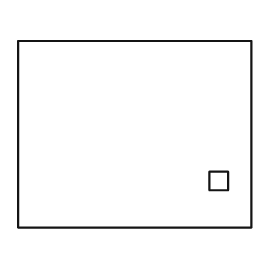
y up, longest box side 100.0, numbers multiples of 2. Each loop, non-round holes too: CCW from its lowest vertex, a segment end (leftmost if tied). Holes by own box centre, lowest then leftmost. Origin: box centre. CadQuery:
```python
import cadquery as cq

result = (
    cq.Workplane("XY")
    .moveTo(-50.0, -40.0)
    .lineTo(50.0, -40.0)
    .lineTo(50.0, 40.0)
    .lineTo(-50.0, 40.0)
    .close()
    .moveTo(32.0, -24.0)
    .lineTo(40.0, -24.0)
    .lineTo(40.0, -16.0)
    .lineTo(32.0, -16.0)
    .close()
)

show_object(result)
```